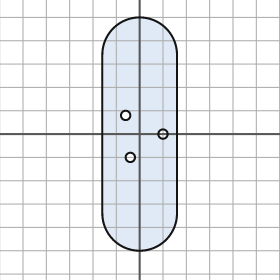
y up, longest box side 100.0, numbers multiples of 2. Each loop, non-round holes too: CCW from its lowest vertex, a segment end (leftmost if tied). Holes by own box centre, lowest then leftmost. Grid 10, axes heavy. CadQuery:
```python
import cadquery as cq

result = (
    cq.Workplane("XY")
    .moveTo(-16.0, -34.0)
    .threePointArc((0.0, -50.0), (16.0, -34.0))
    .lineTo(16.0, 34.0)
    .threePointArc((0.0, 50.0), (-16.0, 34.0))
    .close()
    .moveTo(-4.0, -10.0)
    .circle(2.0)
    .moveTo(10.0, 0.0)
    .circle(2.0)
    .moveTo(-6.0, 8.0)
    .circle(2.0)
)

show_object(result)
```